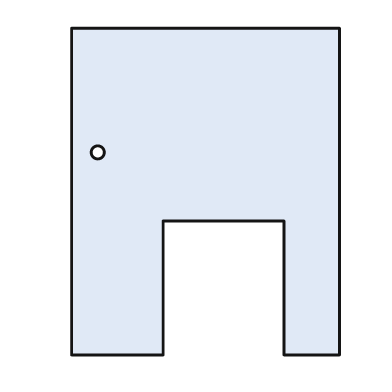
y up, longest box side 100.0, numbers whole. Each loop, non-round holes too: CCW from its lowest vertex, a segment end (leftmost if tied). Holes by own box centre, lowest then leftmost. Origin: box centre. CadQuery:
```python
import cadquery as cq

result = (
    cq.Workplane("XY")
    .moveTo(-41.0, -50.0)
    .lineTo(-13.0, -50.0)
    .lineTo(-13.0, -9.0)
    .lineTo(24.0, -9.0)
    .lineTo(24.0, -50.0)
    .lineTo(41.0, -50.0)
    .lineTo(41.0, 50.0)
    .lineTo(-41.0, 50.0)
    .close()
    .moveTo(-33.0, 12.0)
    .circle(2.0)
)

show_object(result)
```